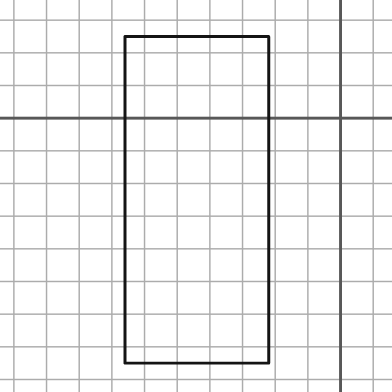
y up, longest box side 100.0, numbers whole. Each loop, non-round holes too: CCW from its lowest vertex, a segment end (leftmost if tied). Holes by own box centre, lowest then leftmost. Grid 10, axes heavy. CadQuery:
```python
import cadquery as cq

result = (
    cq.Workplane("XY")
    .moveTo(-66.0, -75.0)
    .lineTo(-22.0, -75.0)
    .lineTo(-22.0, 25.0)
    .lineTo(-66.0, 25.0)
    .close()
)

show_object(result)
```